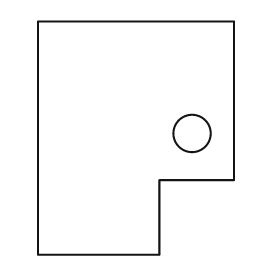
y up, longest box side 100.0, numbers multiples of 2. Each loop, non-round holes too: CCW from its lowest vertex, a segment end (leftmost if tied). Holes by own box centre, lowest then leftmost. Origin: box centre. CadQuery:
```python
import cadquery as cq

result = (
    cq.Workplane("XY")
    .moveTo(-42.0, -50.0)
    .lineTo(10.0, -50.0)
    .lineTo(10.0, -18.0)
    .lineTo(42.0, -18.0)
    .lineTo(42.0, 50.0)
    .lineTo(-42.0, 50.0)
    .close()
    .moveTo(24.0, 2.0)
    .circle(8.0)
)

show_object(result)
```